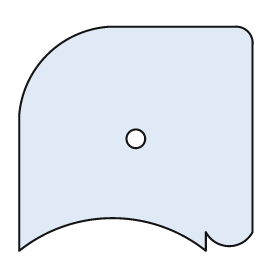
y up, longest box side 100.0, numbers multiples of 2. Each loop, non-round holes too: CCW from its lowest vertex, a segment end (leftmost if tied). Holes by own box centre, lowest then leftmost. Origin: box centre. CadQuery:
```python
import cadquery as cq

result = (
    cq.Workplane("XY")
    .moveTo(-50.0, -48.0)
    .threePointArc((-10.0, -34.0), (30.0, -48.0))
    .lineTo(30.0, -40.0)
    .threePointArc((40.0, -46.0), (50.0, -40.0))
    .lineTo(50.0, 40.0)
    .threePointArc((48.0, 46.0), (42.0, 48.0))
    .lineTo(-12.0, 48.0)
    .threePointArc((-38.0, 36.0), (-50.0, 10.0))
    .close()
    .moveTo(0.0, 0.0)
    .circle(4.0)
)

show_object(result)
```